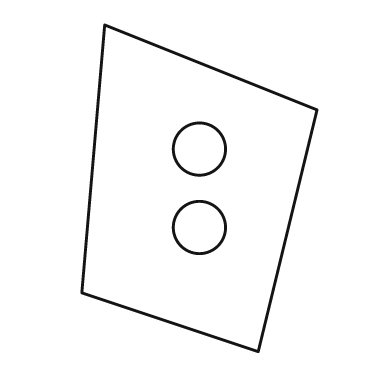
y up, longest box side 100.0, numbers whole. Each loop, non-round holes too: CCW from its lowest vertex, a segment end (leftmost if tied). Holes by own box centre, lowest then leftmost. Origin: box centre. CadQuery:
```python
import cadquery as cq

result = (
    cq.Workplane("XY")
    .moveTo(18.0, -50.0)
    .lineTo(36.0, 24.0)
    .lineTo(-29.0, 50.0)
    .lineTo(-36.0, -32.0)
    .close()
    .moveTo(0.0, -12.0)
    .circle(8.0)
    .moveTo(0.0, 12.0)
    .circle(8.0)
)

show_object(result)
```